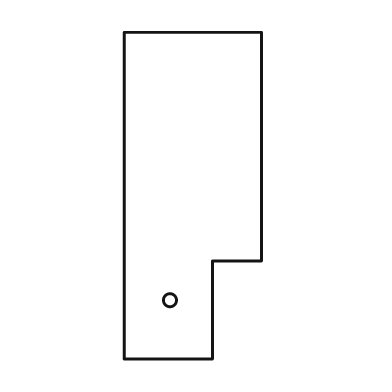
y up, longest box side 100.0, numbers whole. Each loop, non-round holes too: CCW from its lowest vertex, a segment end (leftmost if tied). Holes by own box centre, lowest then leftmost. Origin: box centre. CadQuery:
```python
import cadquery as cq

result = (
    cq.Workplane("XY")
    .moveTo(-21.0, -50.0)
    .lineTo(6.0, -50.0)
    .lineTo(6.0, -20.0)
    .lineTo(21.0, -20.0)
    .lineTo(21.0, 50.0)
    .lineTo(-21.0, 50.0)
    .close()
    .moveTo(-7.0, -32.0)
    .circle(2.0)
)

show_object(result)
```